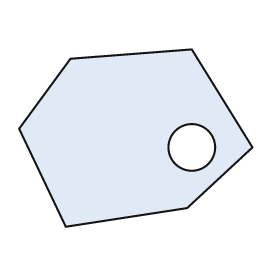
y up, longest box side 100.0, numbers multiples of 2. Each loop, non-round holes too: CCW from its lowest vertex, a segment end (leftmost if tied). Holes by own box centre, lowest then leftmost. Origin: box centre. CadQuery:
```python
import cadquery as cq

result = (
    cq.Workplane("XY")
    .moveTo(-30.0, -38.0)
    .lineTo(22.0, -30.0)
    .lineTo(50.0, -4.0)
    .lineTo(24.0, 38.0)
    .lineTo(-28.0, 34.0)
    .lineTo(-50.0, 4.0)
    .close()
    .moveTo(24.0, -4.0)
    .circle(10.0)
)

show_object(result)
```